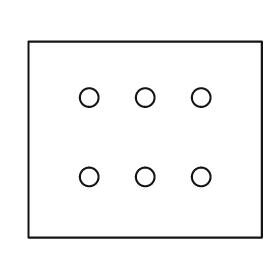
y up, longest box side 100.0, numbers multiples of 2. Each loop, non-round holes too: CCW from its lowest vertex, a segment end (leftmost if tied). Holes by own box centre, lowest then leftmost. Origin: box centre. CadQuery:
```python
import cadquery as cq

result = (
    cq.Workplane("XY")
    .moveTo(-50.0, -42.0)
    .lineTo(50.0, -42.0)
    .lineTo(50.0, 42.0)
    .lineTo(-50.0, 42.0)
    .close()
    .moveTo(-24.0, -16.0)
    .circle(4.0)
    .moveTo(0.0, -16.0)
    .circle(4.0)
    .moveTo(24.0, -16.0)
    .circle(4.0)
    .moveTo(-24.0, 18.0)
    .circle(4.0)
    .moveTo(0.0, 18.0)
    .circle(4.0)
    .moveTo(24.0, 18.0)
    .circle(4.0)
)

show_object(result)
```